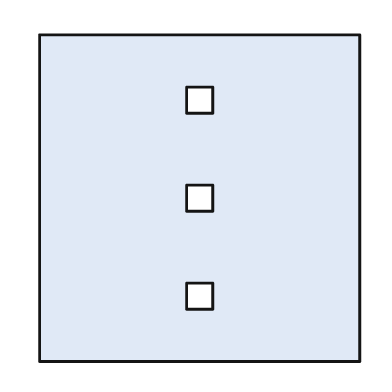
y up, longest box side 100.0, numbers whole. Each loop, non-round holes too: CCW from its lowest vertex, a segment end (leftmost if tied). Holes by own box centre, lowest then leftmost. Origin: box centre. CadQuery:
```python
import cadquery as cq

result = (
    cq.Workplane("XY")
    .moveTo(-49.0, -50.0)
    .lineTo(49.0, -50.0)
    .lineTo(49.0, 50.0)
    .lineTo(-49.0, 50.0)
    .close()
    .moveTo(-4.0, -34.0)
    .lineTo(4.0, -34.0)
    .lineTo(4.0, -26.0)
    .lineTo(-4.0, -26.0)
    .close()
    .moveTo(-4.0, -4.0)
    .lineTo(4.0, -4.0)
    .lineTo(4.0, 4.0)
    .lineTo(-4.0, 4.0)
    .close()
    .moveTo(-4.0, 26.0)
    .lineTo(4.0, 26.0)
    .lineTo(4.0, 34.0)
    .lineTo(-4.0, 34.0)
    .close()
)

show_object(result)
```